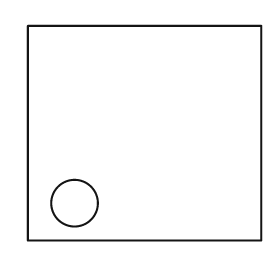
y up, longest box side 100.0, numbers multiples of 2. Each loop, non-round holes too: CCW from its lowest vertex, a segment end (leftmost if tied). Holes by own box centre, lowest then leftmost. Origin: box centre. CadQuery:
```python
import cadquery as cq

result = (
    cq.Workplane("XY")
    .moveTo(-50.0, -46.0)
    .lineTo(50.0, -46.0)
    .lineTo(50.0, 46.0)
    .lineTo(-50.0, 46.0)
    .close()
    .moveTo(-30.0, -30.0)
    .circle(10.0)
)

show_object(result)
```